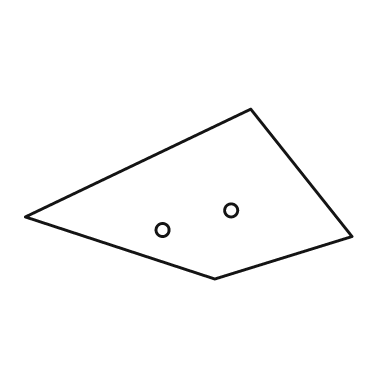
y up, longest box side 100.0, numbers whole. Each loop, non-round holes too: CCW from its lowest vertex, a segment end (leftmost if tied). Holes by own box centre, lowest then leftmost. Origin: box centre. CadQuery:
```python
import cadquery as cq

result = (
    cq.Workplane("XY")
    .moveTo(8.0, -26.0)
    .lineTo(50.0, -13.0)
    .lineTo(19.0, 26.0)
    .lineTo(-50.0, -7.0)
    .close()
    .moveTo(-8.0, -11.0)
    .circle(2.0)
    .moveTo(13.0, -5.0)
    .circle(2.0)
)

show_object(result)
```